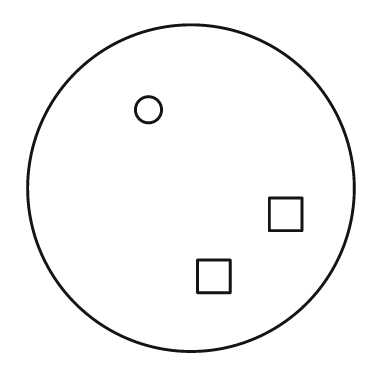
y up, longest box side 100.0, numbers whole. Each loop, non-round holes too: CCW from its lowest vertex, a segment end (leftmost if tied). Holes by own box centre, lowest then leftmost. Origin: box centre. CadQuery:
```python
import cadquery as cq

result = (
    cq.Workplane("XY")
    .moveTo(0.0, 0.0)
    .circle(50.0)
    .moveTo(2.0, -32.0)
    .lineTo(12.0, -32.0)
    .lineTo(12.0, -22.0)
    .lineTo(2.0, -22.0)
    .close()
    .moveTo(24.0, -13.0)
    .lineTo(34.0, -13.0)
    .lineTo(34.0, -3.0)
    .lineTo(24.0, -3.0)
    .close()
    .moveTo(-13.0, 24.0)
    .circle(4.0)
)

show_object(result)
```